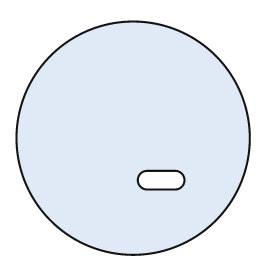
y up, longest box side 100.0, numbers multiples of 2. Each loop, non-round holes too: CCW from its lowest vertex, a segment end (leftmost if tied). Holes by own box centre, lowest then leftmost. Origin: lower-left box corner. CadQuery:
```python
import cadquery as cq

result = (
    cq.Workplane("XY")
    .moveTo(50.0, 50.0)
    .circle(50.0)
    .moveTo(56.0, 28.0)
    .lineTo(68.0, 28.0)
    .threePointArc((72.0, 32.0), (68.0, 36.0))
    .lineTo(56.0, 36.0)
    .threePointArc((52.0, 32.0), (56.0, 28.0))
    .close()
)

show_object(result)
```